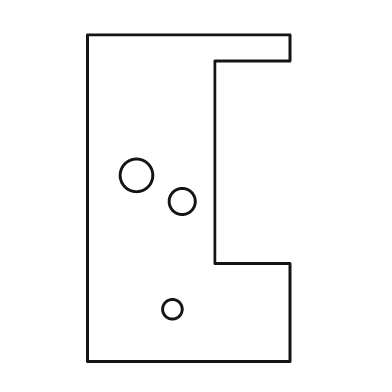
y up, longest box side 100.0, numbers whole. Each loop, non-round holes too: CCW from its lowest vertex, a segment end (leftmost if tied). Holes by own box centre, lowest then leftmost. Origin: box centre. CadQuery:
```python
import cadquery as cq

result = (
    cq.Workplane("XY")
    .moveTo(-31.0, -50.0)
    .lineTo(31.0, -50.0)
    .lineTo(31.0, -20.0)
    .lineTo(8.0, -20.0)
    .lineTo(8.0, 42.0)
    .lineTo(31.0, 42.0)
    .lineTo(31.0, 50.0)
    .lineTo(-31.0, 50.0)
    .close()
    .moveTo(-5.0, -34.0)
    .circle(3.0)
    .moveTo(-2.0, -1.0)
    .circle(4.0)
    .moveTo(-16.0, 7.0)
    .circle(5.0)
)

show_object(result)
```